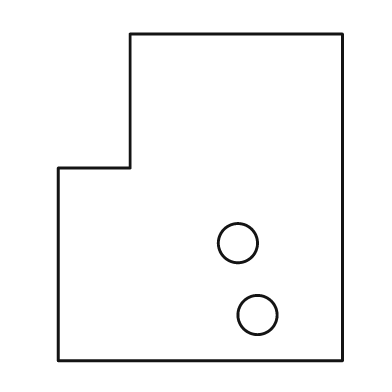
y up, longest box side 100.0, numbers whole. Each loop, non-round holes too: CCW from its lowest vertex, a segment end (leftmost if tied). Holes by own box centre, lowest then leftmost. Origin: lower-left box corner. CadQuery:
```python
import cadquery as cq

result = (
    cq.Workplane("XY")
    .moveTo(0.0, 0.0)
    .lineTo(87.0, 0.0)
    .lineTo(87.0, 100.0)
    .lineTo(22.0, 100.0)
    .lineTo(22.0, 59.0)
    .lineTo(0.0, 59.0)
    .close()
    .moveTo(61.0, 14.0)
    .circle(6.0)
    .moveTo(55.0, 36.0)
    .circle(6.0)
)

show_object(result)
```